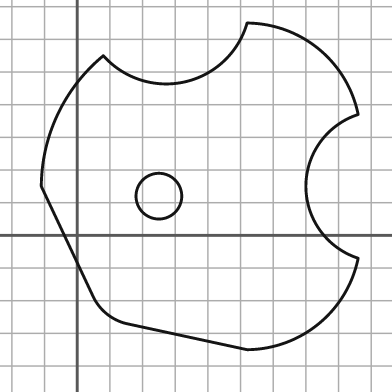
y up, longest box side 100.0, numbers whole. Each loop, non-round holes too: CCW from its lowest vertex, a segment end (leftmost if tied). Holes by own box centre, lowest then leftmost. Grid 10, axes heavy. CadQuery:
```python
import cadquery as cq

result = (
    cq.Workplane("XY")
    .moveTo(52.0, -35.0)
    .threePointArc((74.0, -27.0), (86.0, -7.0))
    .threePointArc((70.0, 15.0), (86.0, 37.0))
    .threePointArc((74.0, 57.0), (52.0, 65.0))
    .threePointArc((33.0, 47.0), (8.0, 55.0))
    .threePointArc((-6.0, 37.0), (-11.0, 15.0))
    .lineTo(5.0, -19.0)
    .threePointArc((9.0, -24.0), (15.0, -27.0))
    .close()
    .moveTo(25.0, 12.0)
    .circle(7.0)
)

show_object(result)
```